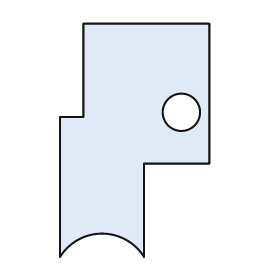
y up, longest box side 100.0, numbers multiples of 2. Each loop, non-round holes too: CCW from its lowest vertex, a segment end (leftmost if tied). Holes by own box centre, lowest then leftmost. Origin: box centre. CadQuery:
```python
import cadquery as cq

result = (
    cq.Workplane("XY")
    .moveTo(-32.0, -50.0)
    .threePointArc((-14.0, -40.0), (4.0, -50.0))
    .lineTo(4.0, -10.0)
    .lineTo(32.0, -10.0)
    .lineTo(32.0, 50.0)
    .lineTo(-22.0, 50.0)
    .lineTo(-22.0, 10.0)
    .lineTo(-32.0, 10.0)
    .close()
    .moveTo(20.0, 12.0)
    .circle(8.0)
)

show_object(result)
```